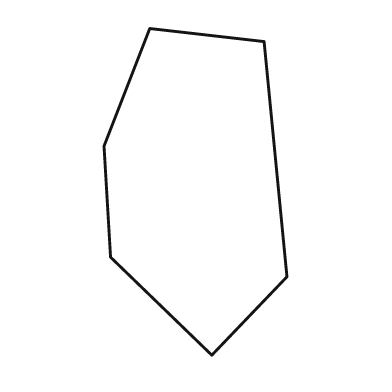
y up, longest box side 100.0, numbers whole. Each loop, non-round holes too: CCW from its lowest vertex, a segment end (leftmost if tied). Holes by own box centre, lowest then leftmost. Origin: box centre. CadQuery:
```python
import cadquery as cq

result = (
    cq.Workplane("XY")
    .moveTo(5.0, -50.0)
    .lineTo(28.0, -26.0)
    .lineTo(21.0, 46.0)
    .lineTo(-14.0, 50.0)
    .lineTo(-28.0, 14.0)
    .lineTo(-26.0, -20.0)
    .close()
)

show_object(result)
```